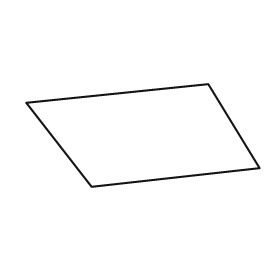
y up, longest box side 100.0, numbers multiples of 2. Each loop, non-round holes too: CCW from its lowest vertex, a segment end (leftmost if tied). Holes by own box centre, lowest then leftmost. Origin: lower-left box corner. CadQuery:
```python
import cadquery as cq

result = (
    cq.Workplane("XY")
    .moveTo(28.0, 0.0)
    .lineTo(100.0, 8.0)
    .lineTo(78.0, 44.0)
    .lineTo(0.0, 36.0)
    .close()
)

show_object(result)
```